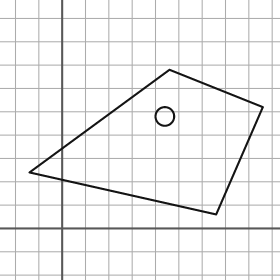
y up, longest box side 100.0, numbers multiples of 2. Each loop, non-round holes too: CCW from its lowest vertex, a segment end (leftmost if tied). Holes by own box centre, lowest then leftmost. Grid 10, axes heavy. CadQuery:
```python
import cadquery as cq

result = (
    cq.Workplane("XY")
    .moveTo(66.0, 6.0)
    .lineTo(86.0, 52.0)
    .lineTo(46.0, 68.0)
    .lineTo(-14.0, 24.0)
    .close()
    .moveTo(44.0, 48.0)
    .circle(4.0)
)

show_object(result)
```